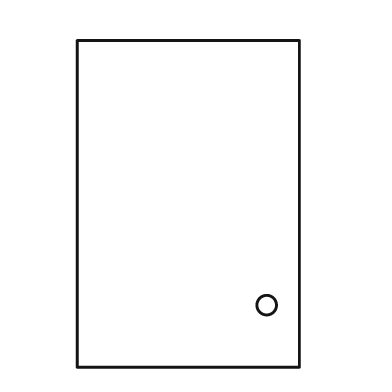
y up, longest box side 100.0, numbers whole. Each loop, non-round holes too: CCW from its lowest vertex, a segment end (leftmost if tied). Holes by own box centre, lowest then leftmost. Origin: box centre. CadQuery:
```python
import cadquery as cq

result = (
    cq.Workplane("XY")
    .moveTo(-34.0, -50.0)
    .lineTo(34.0, -50.0)
    .lineTo(34.0, 50.0)
    .lineTo(-34.0, 50.0)
    .close()
    .moveTo(24.0, -31.0)
    .circle(3.0)
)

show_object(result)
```